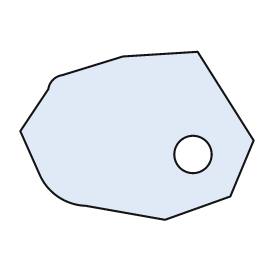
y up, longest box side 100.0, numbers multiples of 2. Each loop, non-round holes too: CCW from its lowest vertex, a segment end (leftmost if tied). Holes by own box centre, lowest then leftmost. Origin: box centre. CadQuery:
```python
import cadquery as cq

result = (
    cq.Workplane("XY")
    .moveTo(12.0, -36.0)
    .lineTo(40.0, -26.0)
    .lineTo(50.0, -2.0)
    .lineTo(26.0, 36.0)
    .lineTo(-6.0, 34.0)
    .lineTo(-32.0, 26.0)
    .threePointArc((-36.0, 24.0), (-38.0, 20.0))
    .lineTo(-50.0, 2.0)
    .lineTo(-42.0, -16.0)
    .threePointArc((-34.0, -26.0), (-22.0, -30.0))
    .close()
    .moveTo(24.0, -8.0)
    .circle(8.0)
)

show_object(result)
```